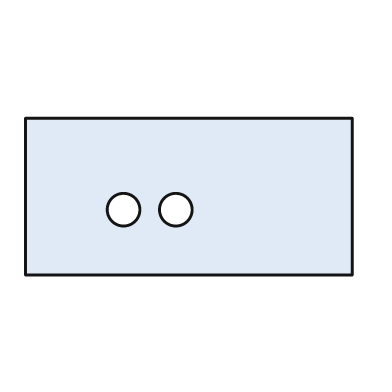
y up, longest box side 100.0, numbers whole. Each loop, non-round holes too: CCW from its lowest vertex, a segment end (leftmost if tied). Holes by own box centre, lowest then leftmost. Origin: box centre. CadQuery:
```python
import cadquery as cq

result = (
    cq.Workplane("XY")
    .moveTo(-50.0, -24.0)
    .lineTo(50.0, -24.0)
    .lineTo(50.0, 24.0)
    .lineTo(-50.0, 24.0)
    .close()
    .moveTo(-20.0, -4.0)
    .circle(5.0)
    .moveTo(-4.0, -4.0)
    .circle(5.0)
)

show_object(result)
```